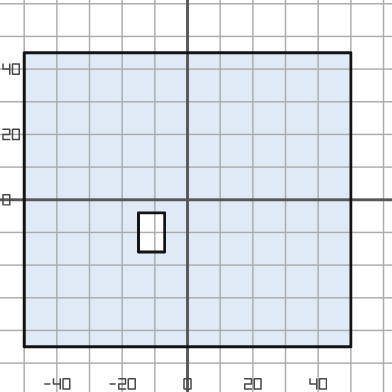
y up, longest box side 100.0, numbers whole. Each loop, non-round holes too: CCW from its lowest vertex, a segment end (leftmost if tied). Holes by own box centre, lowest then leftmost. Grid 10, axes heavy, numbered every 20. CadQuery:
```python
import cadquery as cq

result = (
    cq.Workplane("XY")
    .moveTo(-50.0, -45.0)
    .lineTo(50.0, -45.0)
    .lineTo(50.0, 45.0)
    .lineTo(-50.0, 45.0)
    .close()
    .moveTo(-15.0, -16.0)
    .lineTo(-7.0, -16.0)
    .lineTo(-7.0, -4.0)
    .lineTo(-15.0, -4.0)
    .close()
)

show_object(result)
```